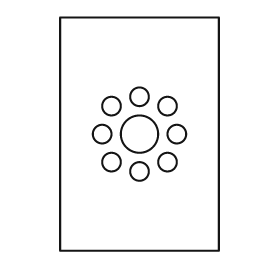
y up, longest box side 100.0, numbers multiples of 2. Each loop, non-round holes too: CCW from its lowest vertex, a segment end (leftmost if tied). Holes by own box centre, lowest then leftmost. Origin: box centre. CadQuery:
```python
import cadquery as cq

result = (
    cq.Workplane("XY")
    .moveTo(-34.0, -50.0)
    .lineTo(34.0, -50.0)
    .lineTo(34.0, 50.0)
    .lineTo(-34.0, 50.0)
    .close()
    .moveTo(0.0, -16.0)
    .circle(4.0)
    .moveTo(-12.0, -12.0)
    .circle(4.0)
    .moveTo(12.0, -12.0)
    .circle(4.0)
    .moveTo(-16.0, 0.0)
    .circle(4.0)
    .moveTo(0.0, 0.0)
    .circle(8.0)
    .moveTo(16.0, 0.0)
    .circle(4.0)
    .moveTo(-12.0, 12.0)
    .circle(4.0)
    .moveTo(12.0, 12.0)
    .circle(4.0)
    .moveTo(0.0, 16.0)
    .circle(4.0)
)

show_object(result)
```